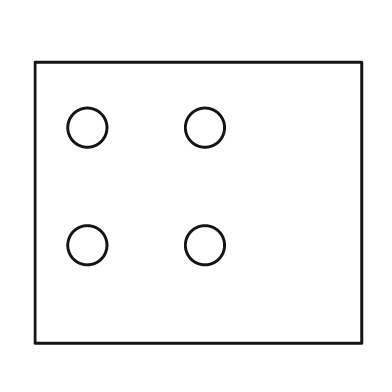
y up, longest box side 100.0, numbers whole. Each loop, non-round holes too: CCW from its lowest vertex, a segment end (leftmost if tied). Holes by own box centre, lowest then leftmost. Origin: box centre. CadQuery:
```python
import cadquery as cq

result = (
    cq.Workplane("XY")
    .moveTo(-50.0, -43.0)
    .lineTo(50.0, -43.0)
    .lineTo(50.0, 43.0)
    .lineTo(-50.0, 43.0)
    .close()
    .moveTo(-34.0, -13.0)
    .circle(6.0)
    .moveTo(2.0, -13.0)
    .circle(6.0)
    .moveTo(-34.0, 23.0)
    .circle(6.0)
    .moveTo(2.0, 23.0)
    .circle(6.0)
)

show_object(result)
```